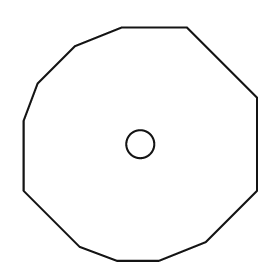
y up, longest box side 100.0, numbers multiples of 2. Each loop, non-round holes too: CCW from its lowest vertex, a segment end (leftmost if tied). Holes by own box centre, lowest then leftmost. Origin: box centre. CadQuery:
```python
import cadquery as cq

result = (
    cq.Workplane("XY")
    .moveTo(-10.0, -50.0)
    .lineTo(8.0, -50.0)
    .lineTo(28.0, -42.0)
    .lineTo(50.0, -20.0)
    .lineTo(50.0, 20.0)
    .lineTo(20.0, 50.0)
    .lineTo(-8.0, 50.0)
    .lineTo(-28.0, 42.0)
    .lineTo(-44.0, 26.0)
    .lineTo(-50.0, 10.0)
    .lineTo(-50.0, -20.0)
    .lineTo(-26.0, -44.0)
    .close()
    .moveTo(0.0, 0.0)
    .circle(6.0)
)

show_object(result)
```